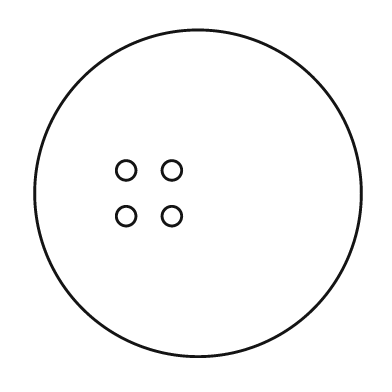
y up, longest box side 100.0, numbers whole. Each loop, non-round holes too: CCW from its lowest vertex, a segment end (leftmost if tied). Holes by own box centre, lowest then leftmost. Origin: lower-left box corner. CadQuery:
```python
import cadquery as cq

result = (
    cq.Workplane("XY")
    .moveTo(50.0, 50.0)
    .circle(50.0)
    .moveTo(28.0, 43.0)
    .circle(3.0)
    .moveTo(42.0, 43.0)
    .circle(3.0)
    .moveTo(28.0, 57.0)
    .circle(3.0)
    .moveTo(42.0, 57.0)
    .circle(3.0)
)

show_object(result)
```